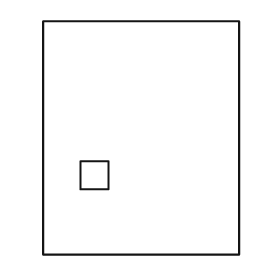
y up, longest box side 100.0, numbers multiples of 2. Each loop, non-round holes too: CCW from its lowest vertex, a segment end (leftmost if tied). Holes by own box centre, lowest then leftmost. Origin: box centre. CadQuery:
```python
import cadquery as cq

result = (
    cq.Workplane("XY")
    .moveTo(-42.0, -50.0)
    .lineTo(42.0, -50.0)
    .lineTo(42.0, 50.0)
    .lineTo(-42.0, 50.0)
    .close()
    .moveTo(-26.0, -22.0)
    .lineTo(-14.0, -22.0)
    .lineTo(-14.0, -10.0)
    .lineTo(-26.0, -10.0)
    .close()
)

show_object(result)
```